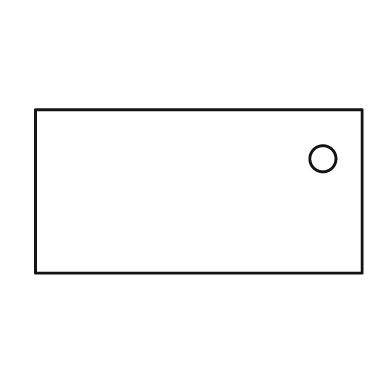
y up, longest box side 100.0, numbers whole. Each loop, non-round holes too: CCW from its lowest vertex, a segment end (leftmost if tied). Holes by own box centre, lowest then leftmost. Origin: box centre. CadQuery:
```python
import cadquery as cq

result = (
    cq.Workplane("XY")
    .moveTo(-50.0, -25.0)
    .lineTo(50.0, -25.0)
    .lineTo(50.0, 25.0)
    .lineTo(-50.0, 25.0)
    .close()
    .moveTo(38.0, 10.0)
    .circle(4.0)
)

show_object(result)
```